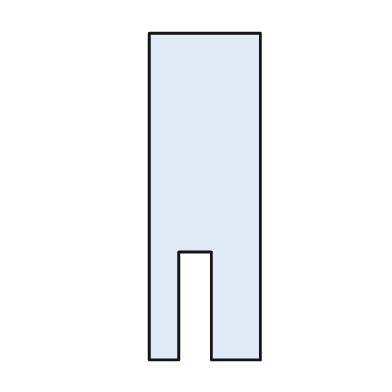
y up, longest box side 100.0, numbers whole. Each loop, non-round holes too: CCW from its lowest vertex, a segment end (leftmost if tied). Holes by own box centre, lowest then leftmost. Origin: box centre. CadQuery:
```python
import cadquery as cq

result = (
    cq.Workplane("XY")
    .moveTo(-17.0, -50.0)
    .lineTo(-8.0, -50.0)
    .lineTo(-8.0, -17.0)
    .lineTo(2.0, -17.0)
    .lineTo(2.0, -50.0)
    .lineTo(17.0, -50.0)
    .lineTo(17.0, 50.0)
    .lineTo(-17.0, 50.0)
    .close()
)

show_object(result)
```